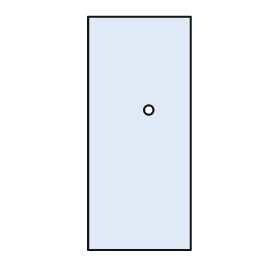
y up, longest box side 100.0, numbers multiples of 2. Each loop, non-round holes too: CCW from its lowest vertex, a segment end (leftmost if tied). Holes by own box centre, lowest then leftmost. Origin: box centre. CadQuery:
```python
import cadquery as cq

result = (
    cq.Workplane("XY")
    .moveTo(-22.0, -50.0)
    .lineTo(22.0, -50.0)
    .lineTo(22.0, 50.0)
    .lineTo(-22.0, 50.0)
    .close()
    .moveTo(4.0, 10.0)
    .circle(2.0)
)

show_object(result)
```